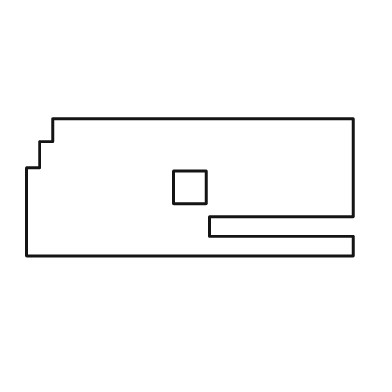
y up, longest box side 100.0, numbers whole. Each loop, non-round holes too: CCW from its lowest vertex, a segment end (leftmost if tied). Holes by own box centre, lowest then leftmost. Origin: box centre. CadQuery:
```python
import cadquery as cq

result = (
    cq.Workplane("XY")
    .moveTo(-50.0, -21.0)
    .lineTo(50.0, -21.0)
    .lineTo(50.0, -15.0)
    .lineTo(6.0, -15.0)
    .lineTo(6.0, -9.0)
    .lineTo(50.0, -9.0)
    .lineTo(50.0, 21.0)
    .lineTo(-42.0, 21.0)
    .lineTo(-42.0, 14.0)
    .lineTo(-46.0, 14.0)
    .lineTo(-46.0, 6.0)
    .lineTo(-50.0, 6.0)
    .close()
    .moveTo(-5.0, -5.0)
    .lineTo(5.0, -5.0)
    .lineTo(5.0, 5.0)
    .lineTo(-5.0, 5.0)
    .close()
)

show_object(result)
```